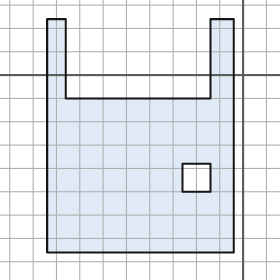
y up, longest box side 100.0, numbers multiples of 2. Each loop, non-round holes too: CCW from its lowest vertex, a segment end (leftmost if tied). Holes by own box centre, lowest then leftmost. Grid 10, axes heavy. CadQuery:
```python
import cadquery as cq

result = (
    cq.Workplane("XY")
    .moveTo(-84.0, -76.0)
    .lineTo(-4.0, -76.0)
    .lineTo(-4.0, 24.0)
    .lineTo(-14.0, 24.0)
    .lineTo(-14.0, -10.0)
    .lineTo(-76.0, -10.0)
    .lineTo(-76.0, 24.0)
    .lineTo(-84.0, 24.0)
    .close()
    .moveTo(-26.0, -50.0)
    .lineTo(-14.0, -50.0)
    .lineTo(-14.0, -38.0)
    .lineTo(-26.0, -38.0)
    .close()
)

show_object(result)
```